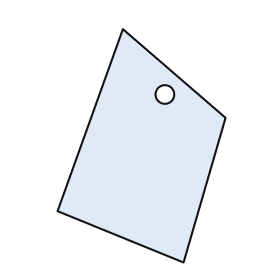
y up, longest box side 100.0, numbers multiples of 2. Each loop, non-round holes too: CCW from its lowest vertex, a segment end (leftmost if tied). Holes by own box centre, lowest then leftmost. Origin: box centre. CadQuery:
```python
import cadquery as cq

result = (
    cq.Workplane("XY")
    .moveTo(18.0, -50.0)
    .lineTo(36.0, 12.0)
    .lineTo(-8.0, 50.0)
    .lineTo(-36.0, -28.0)
    .close()
    .moveTo(10.0, 22.0)
    .circle(4.0)
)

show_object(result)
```